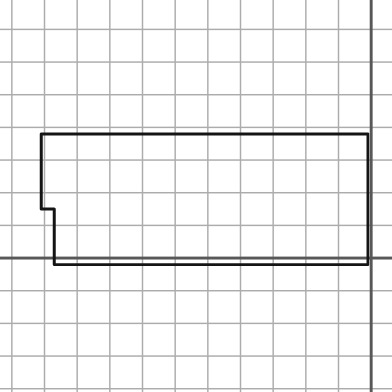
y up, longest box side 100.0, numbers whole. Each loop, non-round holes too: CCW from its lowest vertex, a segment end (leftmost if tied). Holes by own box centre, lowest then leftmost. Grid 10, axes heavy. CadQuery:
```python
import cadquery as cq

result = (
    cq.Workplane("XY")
    .moveTo(-97.0, -2.0)
    .lineTo(-1.0, -2.0)
    .lineTo(-1.0, 38.0)
    .lineTo(-101.0, 38.0)
    .lineTo(-101.0, 15.0)
    .lineTo(-97.0, 15.0)
    .close()
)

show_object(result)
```